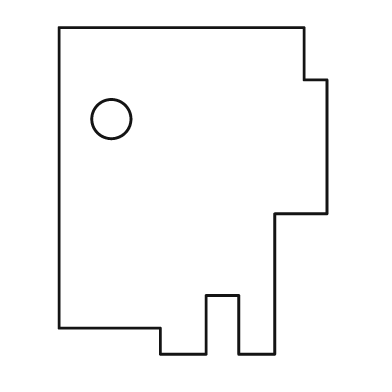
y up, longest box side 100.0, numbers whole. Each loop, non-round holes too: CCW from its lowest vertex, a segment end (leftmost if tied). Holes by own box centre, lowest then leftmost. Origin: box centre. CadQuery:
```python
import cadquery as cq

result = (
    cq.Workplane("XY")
    .moveTo(-10.0, -50.0)
    .lineTo(4.0, -50.0)
    .lineTo(4.0, -32.0)
    .lineTo(14.0, -32.0)
    .lineTo(14.0, -50.0)
    .lineTo(25.0, -50.0)
    .lineTo(25.0, -7.0)
    .lineTo(41.0, -7.0)
    .lineTo(41.0, 34.0)
    .lineTo(34.0, 34.0)
    .lineTo(34.0, 50.0)
    .lineTo(-41.0, 50.0)
    .lineTo(-41.0, -42.0)
    .lineTo(-10.0, -42.0)
    .close()
    .moveTo(-25.0, 22.0)
    .circle(6.0)
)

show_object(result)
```